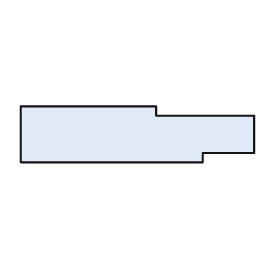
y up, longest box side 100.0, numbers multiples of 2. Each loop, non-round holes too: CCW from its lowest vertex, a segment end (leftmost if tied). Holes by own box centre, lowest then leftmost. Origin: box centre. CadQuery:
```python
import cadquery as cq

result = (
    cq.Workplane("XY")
    .moveTo(-50.0, -12.0)
    .lineTo(28.0, -12.0)
    .lineTo(28.0, -8.0)
    .lineTo(50.0, -8.0)
    .lineTo(50.0, 8.0)
    .lineTo(8.0, 8.0)
    .lineTo(8.0, 12.0)
    .lineTo(-50.0, 12.0)
    .close()
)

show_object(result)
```